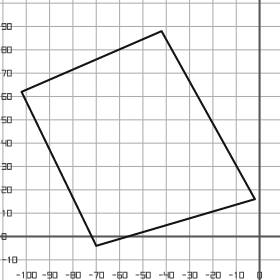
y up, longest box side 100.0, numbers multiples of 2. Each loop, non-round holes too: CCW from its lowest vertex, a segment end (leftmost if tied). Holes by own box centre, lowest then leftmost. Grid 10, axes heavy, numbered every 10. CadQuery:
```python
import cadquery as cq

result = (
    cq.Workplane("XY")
    .moveTo(-70.0, -4.0)
    .lineTo(-2.0, 16.0)
    .lineTo(-42.0, 88.0)
    .lineTo(-102.0, 62.0)
    .close()
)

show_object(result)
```